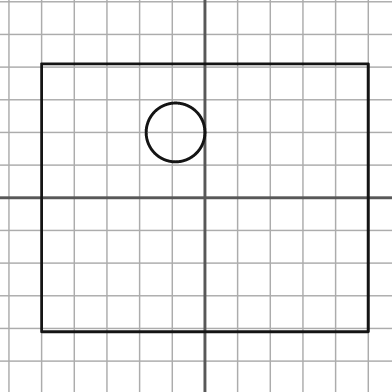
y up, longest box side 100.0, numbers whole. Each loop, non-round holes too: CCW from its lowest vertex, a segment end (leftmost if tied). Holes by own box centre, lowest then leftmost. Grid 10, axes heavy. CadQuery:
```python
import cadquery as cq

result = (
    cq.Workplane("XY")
    .moveTo(-50.0, -41.0)
    .lineTo(50.0, -41.0)
    .lineTo(50.0, 41.0)
    .lineTo(-50.0, 41.0)
    .close()
    .moveTo(-9.0, 20.0)
    .circle(9.0)
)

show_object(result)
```